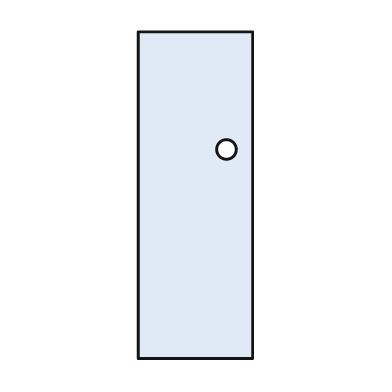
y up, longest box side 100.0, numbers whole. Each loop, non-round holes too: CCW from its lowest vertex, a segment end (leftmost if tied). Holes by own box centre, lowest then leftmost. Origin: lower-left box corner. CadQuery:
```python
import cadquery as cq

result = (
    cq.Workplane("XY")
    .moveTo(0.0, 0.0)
    .lineTo(35.0, 0.0)
    .lineTo(35.0, 100.0)
    .lineTo(0.0, 100.0)
    .close()
    .moveTo(27.0, 64.0)
    .circle(3.0)
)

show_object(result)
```